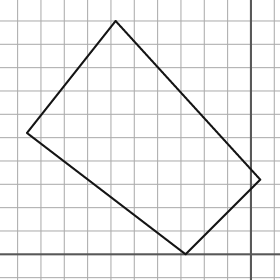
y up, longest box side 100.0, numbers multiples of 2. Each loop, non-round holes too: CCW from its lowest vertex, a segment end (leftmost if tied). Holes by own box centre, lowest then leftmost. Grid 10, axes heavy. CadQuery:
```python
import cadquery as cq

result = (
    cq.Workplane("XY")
    .moveTo(-28.0, 0.0)
    .lineTo(4.0, 32.0)
    .lineTo(-58.0, 100.0)
    .lineTo(-96.0, 52.0)
    .close()
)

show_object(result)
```